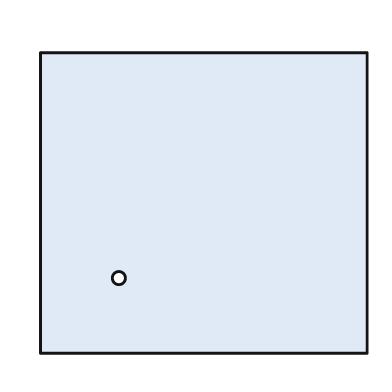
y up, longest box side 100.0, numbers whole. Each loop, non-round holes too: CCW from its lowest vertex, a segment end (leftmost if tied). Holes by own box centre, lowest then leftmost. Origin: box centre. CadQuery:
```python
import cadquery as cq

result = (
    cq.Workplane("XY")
    .moveTo(-50.0, -46.0)
    .lineTo(50.0, -46.0)
    .lineTo(50.0, 46.0)
    .lineTo(-50.0, 46.0)
    .close()
    .moveTo(-26.0, -23.0)
    .circle(2.0)
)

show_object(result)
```